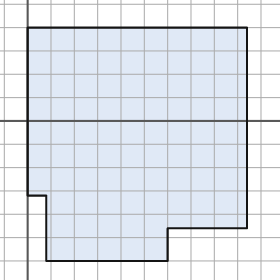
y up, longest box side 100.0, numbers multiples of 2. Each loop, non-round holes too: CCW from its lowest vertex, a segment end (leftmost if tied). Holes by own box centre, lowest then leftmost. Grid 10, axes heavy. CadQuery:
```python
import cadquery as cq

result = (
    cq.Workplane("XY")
    .moveTo(8.0, -60.0)
    .lineTo(60.0, -60.0)
    .lineTo(60.0, -46.0)
    .lineTo(94.0, -46.0)
    .lineTo(94.0, 40.0)
    .lineTo(0.0, 40.0)
    .lineTo(0.0, -32.0)
    .lineTo(8.0, -32.0)
    .close()
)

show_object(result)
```